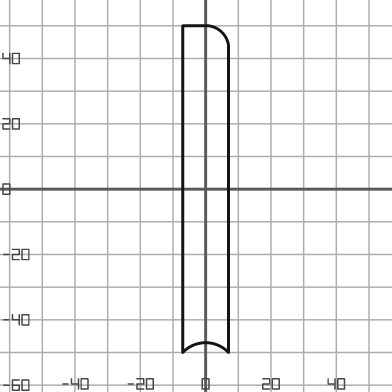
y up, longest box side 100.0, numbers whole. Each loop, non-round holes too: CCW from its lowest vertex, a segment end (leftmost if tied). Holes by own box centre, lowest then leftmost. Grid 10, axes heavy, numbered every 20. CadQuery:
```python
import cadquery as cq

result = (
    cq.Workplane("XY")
    .moveTo(-7.0, -50.0)
    .threePointArc((0.0, -47.0), (7.0, -50.0))
    .lineTo(7.0, 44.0)
    .threePointArc((5.0, 48.0), (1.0, 50.0))
    .lineTo(-7.0, 50.0)
    .close()
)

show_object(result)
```